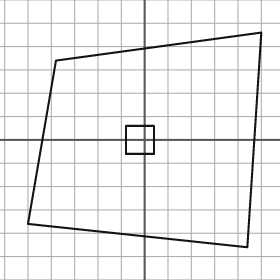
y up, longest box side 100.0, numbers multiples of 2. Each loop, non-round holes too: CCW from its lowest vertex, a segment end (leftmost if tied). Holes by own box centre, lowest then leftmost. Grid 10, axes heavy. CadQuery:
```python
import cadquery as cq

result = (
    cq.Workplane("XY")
    .moveTo(44.0, -46.0)
    .lineTo(50.0, 46.0)
    .lineTo(-38.0, 34.0)
    .lineTo(-50.0, -36.0)
    .close()
    .moveTo(-8.0, -6.0)
    .lineTo(4.0, -6.0)
    .lineTo(4.0, 6.0)
    .lineTo(-8.0, 6.0)
    .close()
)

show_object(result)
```